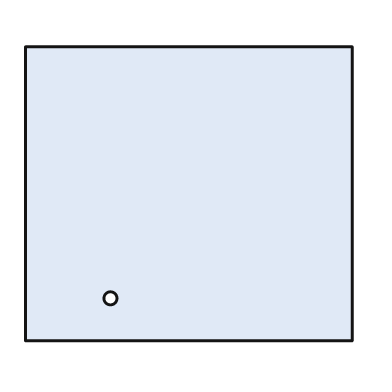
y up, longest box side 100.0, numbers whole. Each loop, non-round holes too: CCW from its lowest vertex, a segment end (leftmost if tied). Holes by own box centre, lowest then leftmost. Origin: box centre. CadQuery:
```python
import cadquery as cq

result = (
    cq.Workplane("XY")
    .moveTo(-50.0, -45.0)
    .lineTo(50.0, -45.0)
    .lineTo(50.0, 45.0)
    .lineTo(-50.0, 45.0)
    .close()
    .moveTo(-24.0, -32.0)
    .circle(2.0)
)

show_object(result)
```